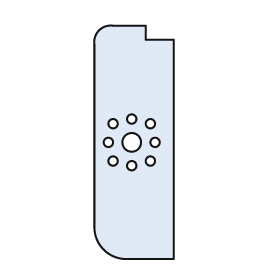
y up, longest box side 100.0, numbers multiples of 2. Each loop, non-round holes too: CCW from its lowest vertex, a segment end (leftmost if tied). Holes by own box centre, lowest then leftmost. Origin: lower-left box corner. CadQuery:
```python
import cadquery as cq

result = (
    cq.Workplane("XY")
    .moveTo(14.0, 0.0)
    .lineTo(34.0, 0.0)
    .lineTo(34.0, 94.0)
    .lineTo(22.0, 94.0)
    .lineTo(22.0, 100.0)
    .lineTo(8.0, 100.0)
    .threePointArc((2.0, 98.0), (0.0, 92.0))
    .lineTo(0.0, 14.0)
    .threePointArc((4.0, 4.0), (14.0, 0.0))
    .close()
    .moveTo(16.0, 40.0)
    .circle(2.0)
    .moveTo(8.0, 42.0)
    .circle(2.0)
    .moveTo(24.0, 42.0)
    .circle(2.0)
    .moveTo(6.0, 50.0)
    .circle(2.0)
    .moveTo(16.0, 50.0)
    .circle(4.0)
    .moveTo(26.0, 50.0)
    .circle(2.0)
    .moveTo(8.0, 58.0)
    .circle(2.0)
    .moveTo(24.0, 58.0)
    .circle(2.0)
    .moveTo(16.0, 60.0)
    .circle(2.0)
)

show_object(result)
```